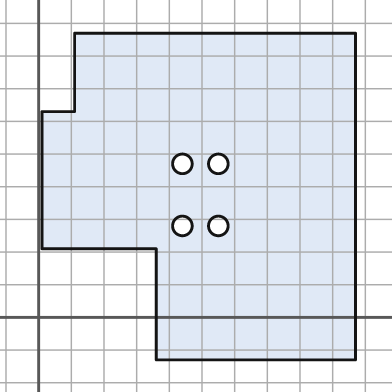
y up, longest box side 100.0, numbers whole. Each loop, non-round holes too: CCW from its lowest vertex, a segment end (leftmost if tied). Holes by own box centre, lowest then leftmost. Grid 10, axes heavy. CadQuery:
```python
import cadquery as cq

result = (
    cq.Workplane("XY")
    .moveTo(36.0, -13.0)
    .lineTo(97.0, -13.0)
    .lineTo(97.0, 87.0)
    .lineTo(11.0, 87.0)
    .lineTo(11.0, 63.0)
    .lineTo(1.0, 63.0)
    .lineTo(1.0, 21.0)
    .lineTo(36.0, 21.0)
    .close()
    .moveTo(44.0, 28.0)
    .circle(3.0)
    .moveTo(55.0, 28.0)
    .circle(3.0)
    .moveTo(44.0, 47.0)
    .circle(3.0)
    .moveTo(55.0, 47.0)
    .circle(3.0)
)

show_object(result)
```